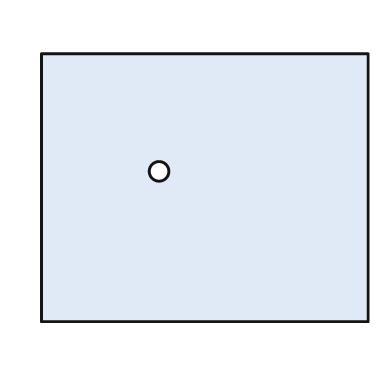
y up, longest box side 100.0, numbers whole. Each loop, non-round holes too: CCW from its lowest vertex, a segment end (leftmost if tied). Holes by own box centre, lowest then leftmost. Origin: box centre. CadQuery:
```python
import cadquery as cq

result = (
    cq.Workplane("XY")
    .moveTo(-50.0, -41.0)
    .lineTo(50.0, -41.0)
    .lineTo(50.0, 41.0)
    .lineTo(-50.0, 41.0)
    .close()
    .moveTo(-14.0, 5.0)
    .circle(3.0)
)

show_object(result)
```